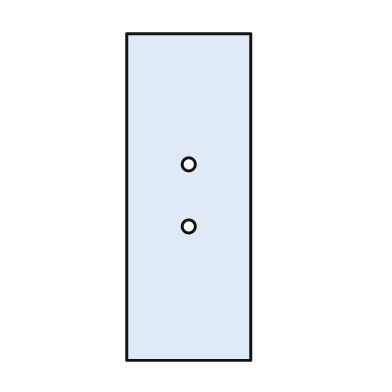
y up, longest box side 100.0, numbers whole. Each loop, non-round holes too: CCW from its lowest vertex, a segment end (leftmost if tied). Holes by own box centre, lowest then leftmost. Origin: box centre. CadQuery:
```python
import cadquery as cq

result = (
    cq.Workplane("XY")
    .moveTo(-19.0, -50.0)
    .lineTo(19.0, -50.0)
    .lineTo(19.0, 50.0)
    .lineTo(-19.0, 50.0)
    .close()
    .moveTo(0.0, -9.0)
    .circle(2.0)
    .moveTo(0.0, 10.0)
    .circle(2.0)
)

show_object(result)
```